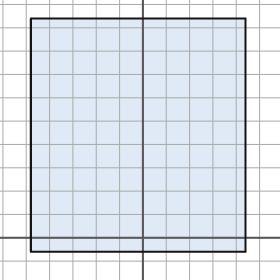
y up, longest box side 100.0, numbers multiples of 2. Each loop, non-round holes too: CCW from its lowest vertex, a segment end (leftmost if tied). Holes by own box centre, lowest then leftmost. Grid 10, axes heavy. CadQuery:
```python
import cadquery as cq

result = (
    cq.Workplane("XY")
    .moveTo(-48.0, -6.0)
    .lineTo(44.0, -6.0)
    .lineTo(44.0, 94.0)
    .lineTo(-48.0, 94.0)
    .close()
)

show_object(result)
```